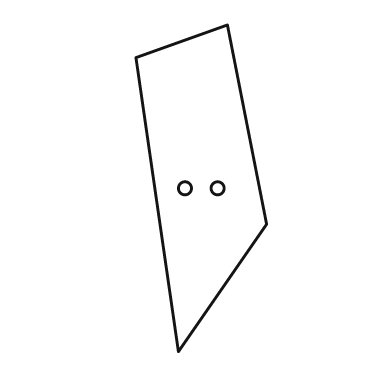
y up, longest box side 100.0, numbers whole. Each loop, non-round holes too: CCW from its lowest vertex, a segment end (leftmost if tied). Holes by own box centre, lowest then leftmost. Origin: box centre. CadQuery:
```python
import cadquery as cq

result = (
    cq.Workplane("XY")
    .moveTo(-7.0, -50.0)
    .lineTo(20.0, -11.0)
    .lineTo(8.0, 50.0)
    .lineTo(-20.0, 40.0)
    .close()
    .moveTo(-5.0, 0.0)
    .circle(2.0)
    .moveTo(5.0, 0.0)
    .circle(2.0)
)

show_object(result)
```